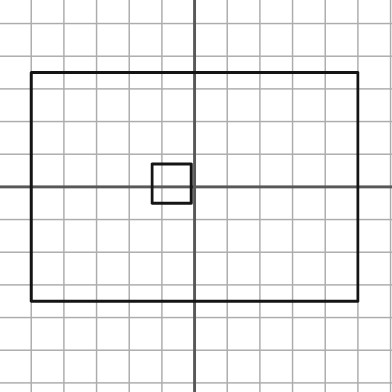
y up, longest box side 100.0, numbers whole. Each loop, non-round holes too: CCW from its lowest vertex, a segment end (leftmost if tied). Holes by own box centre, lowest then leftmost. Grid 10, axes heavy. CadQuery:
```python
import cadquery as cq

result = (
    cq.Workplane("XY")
    .moveTo(-50.0, -35.0)
    .lineTo(50.0, -35.0)
    .lineTo(50.0, 35.0)
    .lineTo(-50.0, 35.0)
    .close()
    .moveTo(-13.0, -5.0)
    .lineTo(-1.0, -5.0)
    .lineTo(-1.0, 7.0)
    .lineTo(-13.0, 7.0)
    .close()
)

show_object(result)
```